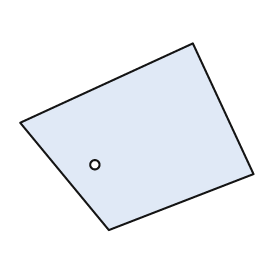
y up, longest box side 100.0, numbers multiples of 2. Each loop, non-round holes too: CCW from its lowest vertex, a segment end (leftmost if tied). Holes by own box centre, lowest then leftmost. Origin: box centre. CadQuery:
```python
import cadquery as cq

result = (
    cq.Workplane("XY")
    .moveTo(-12.0, -40.0)
    .lineTo(50.0, -16.0)
    .lineTo(24.0, 40.0)
    .lineTo(-50.0, 6.0)
    .close()
    .moveTo(-18.0, -12.0)
    .circle(2.0)
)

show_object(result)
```